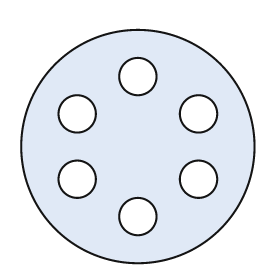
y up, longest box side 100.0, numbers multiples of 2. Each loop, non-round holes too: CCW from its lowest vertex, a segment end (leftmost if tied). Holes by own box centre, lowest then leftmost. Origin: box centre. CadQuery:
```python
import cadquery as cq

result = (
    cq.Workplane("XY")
    .moveTo(0.0, 0.0)
    .circle(50.0)
    .moveTo(0.0, -30.0)
    .circle(8.0)
    .moveTo(-26.0, -14.0)
    .circle(8.0)
    .moveTo(26.0, -14.0)
    .circle(8.0)
    .moveTo(-26.0, 14.0)
    .circle(8.0)
    .moveTo(26.0, 14.0)
    .circle(8.0)
    .moveTo(0.0, 30.0)
    .circle(8.0)
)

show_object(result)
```